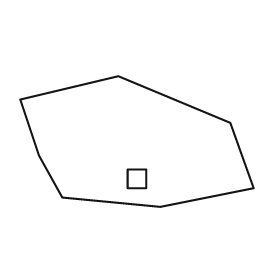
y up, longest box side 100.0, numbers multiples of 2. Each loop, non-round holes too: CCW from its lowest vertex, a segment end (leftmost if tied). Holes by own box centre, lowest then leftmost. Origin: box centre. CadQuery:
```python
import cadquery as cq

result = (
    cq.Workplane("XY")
    .moveTo(10.0, -28.0)
    .lineTo(50.0, -20.0)
    .lineTo(40.0, 8.0)
    .lineTo(-8.0, 28.0)
    .lineTo(-50.0, 18.0)
    .lineTo(-42.0, -6.0)
    .lineTo(-32.0, -24.0)
    .close()
    .moveTo(-4.0, -20.0)
    .lineTo(4.0, -20.0)
    .lineTo(4.0, -12.0)
    .lineTo(-4.0, -12.0)
    .close()
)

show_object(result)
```